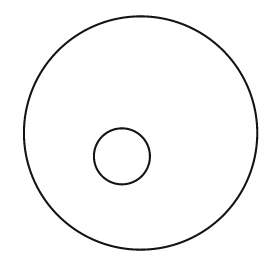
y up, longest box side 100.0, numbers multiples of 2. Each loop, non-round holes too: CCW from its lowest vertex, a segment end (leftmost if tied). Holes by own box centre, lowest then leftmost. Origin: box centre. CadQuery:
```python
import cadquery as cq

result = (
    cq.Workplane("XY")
    .moveTo(0.0, 0.0)
    .circle(50.0)
    .moveTo(-8.0, -10.0)
    .circle(12.0)
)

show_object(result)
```